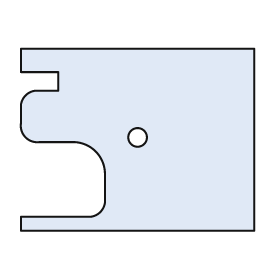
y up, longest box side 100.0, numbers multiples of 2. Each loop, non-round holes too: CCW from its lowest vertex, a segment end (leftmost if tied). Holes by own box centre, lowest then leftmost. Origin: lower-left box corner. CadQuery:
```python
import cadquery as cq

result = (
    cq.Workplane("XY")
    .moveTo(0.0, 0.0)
    .lineTo(100.0, 0.0)
    .lineTo(100.0, 78.0)
    .lineTo(0.0, 78.0)
    .lineTo(0.0, 68.0)
    .lineTo(16.0, 68.0)
    .lineTo(16.0, 60.0)
    .lineTo(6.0, 60.0)
    .threePointArc((2.0, 58.0), (0.0, 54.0))
    .lineTo(0.0, 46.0)
    .threePointArc((2.0, 40.0), (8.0, 38.0))
    .lineTo(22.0, 38.0)
    .threePointArc((32.0, 34.0), (36.0, 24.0))
    .lineTo(36.0, 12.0)
    .threePointArc((34.0, 8.0), (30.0, 6.0))
    .lineTo(0.0, 6.0)
    .close()
    .moveTo(50.0, 40.0)
    .circle(4.0)
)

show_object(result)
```